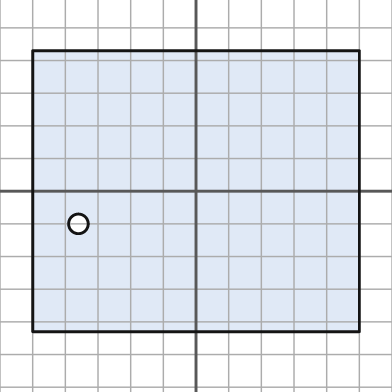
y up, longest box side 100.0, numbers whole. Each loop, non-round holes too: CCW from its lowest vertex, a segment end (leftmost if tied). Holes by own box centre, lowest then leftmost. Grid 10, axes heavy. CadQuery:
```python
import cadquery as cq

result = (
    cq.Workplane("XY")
    .moveTo(-50.0, -43.0)
    .lineTo(50.0, -43.0)
    .lineTo(50.0, 43.0)
    .lineTo(-50.0, 43.0)
    .close()
    .moveTo(-36.0, -10.0)
    .circle(3.0)
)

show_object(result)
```